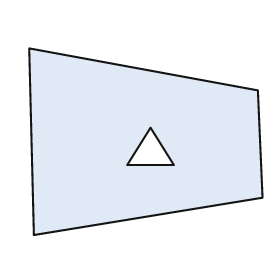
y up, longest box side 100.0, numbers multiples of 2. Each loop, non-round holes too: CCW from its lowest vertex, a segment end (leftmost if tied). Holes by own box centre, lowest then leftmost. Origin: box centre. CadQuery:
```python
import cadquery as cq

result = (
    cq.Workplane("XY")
    .moveTo(-48.0, -40.0)
    .lineTo(50.0, -24.0)
    .lineTo(48.0, 22.0)
    .lineTo(-50.0, 40.0)
    .close()
    .moveTo(-8.0, -10.0)
    .lineTo(12.0, -10.0)
    .lineTo(2.0, 6.0)
    .close()
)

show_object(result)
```